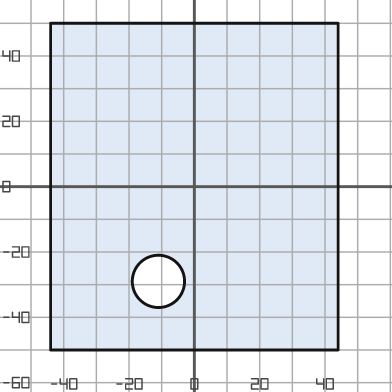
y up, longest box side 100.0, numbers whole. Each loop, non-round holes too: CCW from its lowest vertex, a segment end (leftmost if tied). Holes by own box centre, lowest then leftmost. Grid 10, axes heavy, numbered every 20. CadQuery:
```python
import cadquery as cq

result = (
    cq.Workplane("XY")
    .moveTo(-44.0, -50.0)
    .lineTo(44.0, -50.0)
    .lineTo(44.0, 50.0)
    .lineTo(-44.0, 50.0)
    .close()
    .moveTo(-11.0, -29.0)
    .circle(8.0)
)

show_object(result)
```